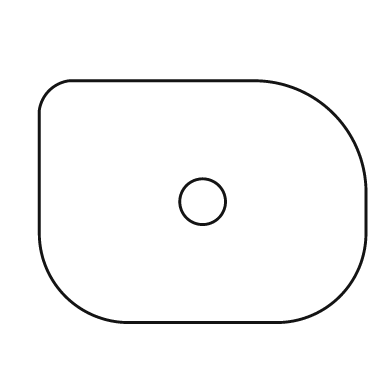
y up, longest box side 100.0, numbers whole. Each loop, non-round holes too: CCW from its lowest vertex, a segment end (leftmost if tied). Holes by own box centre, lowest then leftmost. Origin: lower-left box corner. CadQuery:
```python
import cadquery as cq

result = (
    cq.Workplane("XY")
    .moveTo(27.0, 0.0)
    .lineTo(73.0, 0.0)
    .threePointArc((92.0, 8.0), (100.0, 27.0))
    .lineTo(100.0, 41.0)
    .threePointArc((90.0, 64.0), (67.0, 74.0))
    .lineTo(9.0, 74.0)
    .threePointArc((3.0, 71.0), (0.0, 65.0))
    .lineTo(0.0, 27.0)
    .threePointArc((8.0, 8.0), (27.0, 0.0))
    .close()
    .moveTo(50.0, 37.0)
    .circle(7.0)
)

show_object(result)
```